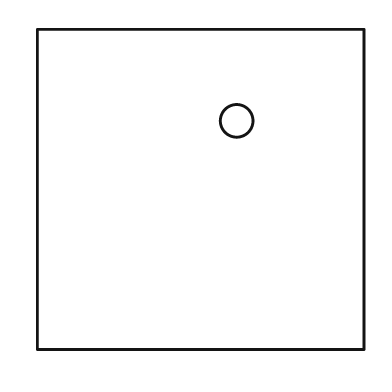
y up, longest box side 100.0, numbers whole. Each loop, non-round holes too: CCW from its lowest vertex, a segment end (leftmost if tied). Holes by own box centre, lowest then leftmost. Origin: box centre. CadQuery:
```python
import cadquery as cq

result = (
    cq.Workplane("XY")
    .moveTo(-50.0, -49.0)
    .lineTo(50.0, -49.0)
    .lineTo(50.0, 49.0)
    .lineTo(-50.0, 49.0)
    .close()
    .moveTo(11.0, 21.0)
    .circle(5.0)
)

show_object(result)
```